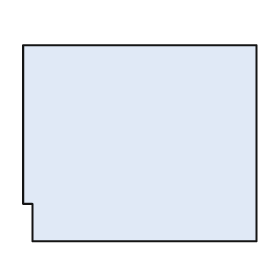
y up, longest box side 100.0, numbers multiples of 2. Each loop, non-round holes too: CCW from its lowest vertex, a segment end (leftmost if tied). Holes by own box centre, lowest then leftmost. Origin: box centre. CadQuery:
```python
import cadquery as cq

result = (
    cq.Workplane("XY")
    .moveTo(-46.0, -42.0)
    .lineTo(50.0, -42.0)
    .lineTo(50.0, 42.0)
    .lineTo(-50.0, 42.0)
    .lineTo(-50.0, -26.0)
    .lineTo(-46.0, -26.0)
    .close()
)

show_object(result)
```